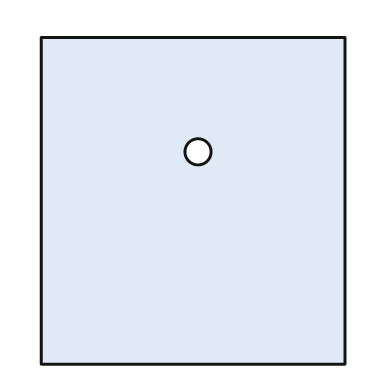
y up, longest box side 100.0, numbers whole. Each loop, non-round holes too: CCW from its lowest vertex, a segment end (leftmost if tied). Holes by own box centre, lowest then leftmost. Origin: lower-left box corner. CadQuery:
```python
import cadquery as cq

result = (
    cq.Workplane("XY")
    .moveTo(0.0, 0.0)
    .lineTo(93.0, 0.0)
    .lineTo(93.0, 100.0)
    .lineTo(0.0, 100.0)
    .close()
    .moveTo(48.0, 65.0)
    .circle(4.0)
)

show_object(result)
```